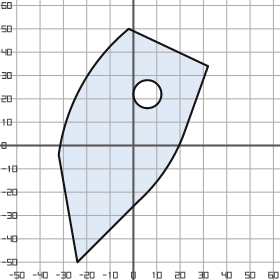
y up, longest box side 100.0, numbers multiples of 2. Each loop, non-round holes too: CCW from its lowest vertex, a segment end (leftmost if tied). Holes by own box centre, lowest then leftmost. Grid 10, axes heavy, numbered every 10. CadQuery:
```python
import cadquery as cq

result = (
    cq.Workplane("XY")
    .moveTo(-24.0, -50.0)
    .lineTo(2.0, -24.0)
    .threePointArc((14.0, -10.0), (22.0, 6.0))
    .lineTo(32.0, 34.0)
    .lineTo(-2.0, 50.0)
    .threePointArc((-22.0, 26.0), (-32.0, -4.0))
    .close()
    .moveTo(6.0, 22.0)
    .circle(6.0)
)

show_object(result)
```